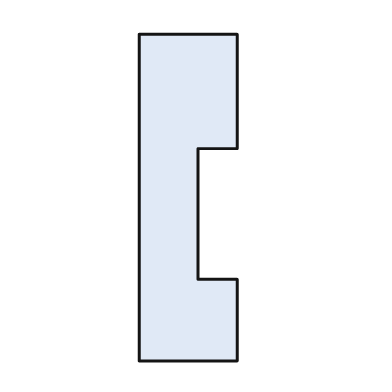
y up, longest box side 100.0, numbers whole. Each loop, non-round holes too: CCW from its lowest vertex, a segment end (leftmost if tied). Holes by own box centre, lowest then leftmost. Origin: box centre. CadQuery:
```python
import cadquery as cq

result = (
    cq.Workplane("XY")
    .moveTo(-15.0, -50.0)
    .lineTo(15.0, -50.0)
    .lineTo(15.0, -25.0)
    .lineTo(3.0, -25.0)
    .lineTo(3.0, 15.0)
    .lineTo(15.0, 15.0)
    .lineTo(15.0, 50.0)
    .lineTo(-15.0, 50.0)
    .close()
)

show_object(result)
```